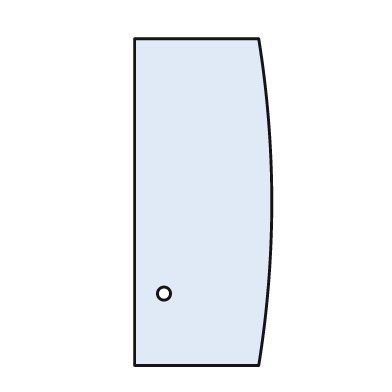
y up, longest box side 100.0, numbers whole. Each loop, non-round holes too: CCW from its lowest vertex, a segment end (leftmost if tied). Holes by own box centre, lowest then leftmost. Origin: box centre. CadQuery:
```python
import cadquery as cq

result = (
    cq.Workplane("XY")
    .moveTo(-21.0, -50.0)
    .lineTo(17.0, -50.0)
    .threePointArc((21.0, 0.0), (17.0, 50.0))
    .lineTo(-21.0, 50.0)
    .close()
    .moveTo(-12.0, -28.0)
    .circle(2.0)
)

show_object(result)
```